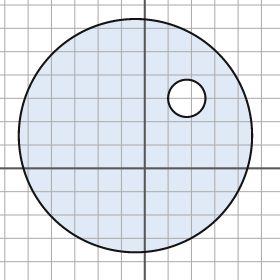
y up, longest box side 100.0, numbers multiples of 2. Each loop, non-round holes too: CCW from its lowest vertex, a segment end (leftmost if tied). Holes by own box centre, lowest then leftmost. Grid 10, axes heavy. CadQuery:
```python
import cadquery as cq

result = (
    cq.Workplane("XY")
    .moveTo(-4.0, 14.0)
    .circle(50.0)
    .moveTo(18.0, 30.0)
    .circle(8.0)
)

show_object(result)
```